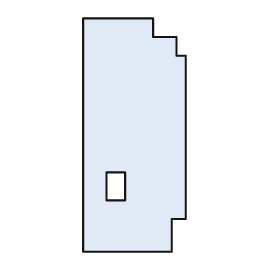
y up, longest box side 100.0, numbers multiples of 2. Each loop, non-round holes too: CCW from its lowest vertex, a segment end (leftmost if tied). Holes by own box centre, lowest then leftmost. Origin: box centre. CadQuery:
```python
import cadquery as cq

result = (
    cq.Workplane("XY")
    .moveTo(-22.0, -50.0)
    .lineTo(16.0, -50.0)
    .lineTo(16.0, -36.0)
    .lineTo(22.0, -36.0)
    .lineTo(22.0, 34.0)
    .lineTo(18.0, 34.0)
    .lineTo(18.0, 42.0)
    .lineTo(8.0, 42.0)
    .lineTo(8.0, 50.0)
    .lineTo(-22.0, 50.0)
    .close()
    .moveTo(-12.0, -28.0)
    .lineTo(-4.0, -28.0)
    .lineTo(-4.0, -16.0)
    .lineTo(-12.0, -16.0)
    .close()
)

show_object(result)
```